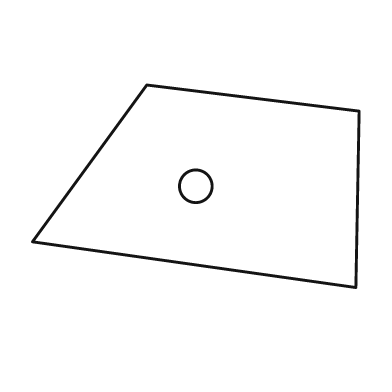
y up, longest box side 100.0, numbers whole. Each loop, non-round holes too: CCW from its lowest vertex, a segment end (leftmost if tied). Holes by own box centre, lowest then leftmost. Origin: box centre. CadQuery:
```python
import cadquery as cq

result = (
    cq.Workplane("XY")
    .moveTo(49.0, -31.0)
    .lineTo(50.0, 23.0)
    .lineTo(-15.0, 31.0)
    .lineTo(-50.0, -17.0)
    .close()
    .moveTo(0.0, 0.0)
    .circle(5.0)
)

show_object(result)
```